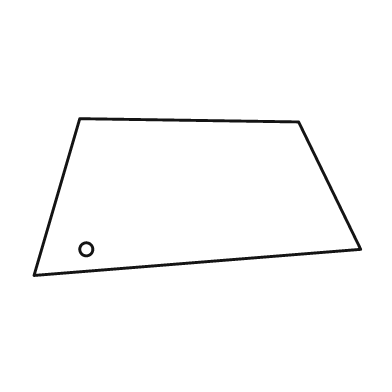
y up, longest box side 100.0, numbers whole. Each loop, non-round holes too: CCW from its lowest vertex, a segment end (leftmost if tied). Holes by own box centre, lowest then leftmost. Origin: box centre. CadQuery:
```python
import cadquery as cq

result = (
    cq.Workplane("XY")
    .moveTo(-50.0, -24.0)
    .lineTo(50.0, -16.0)
    .lineTo(31.0, 23.0)
    .lineTo(-36.0, 24.0)
    .close()
    .moveTo(-34.0, -16.0)
    .circle(2.0)
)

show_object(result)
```